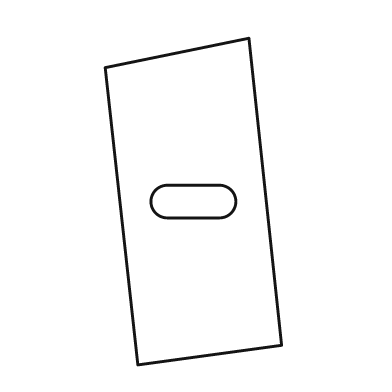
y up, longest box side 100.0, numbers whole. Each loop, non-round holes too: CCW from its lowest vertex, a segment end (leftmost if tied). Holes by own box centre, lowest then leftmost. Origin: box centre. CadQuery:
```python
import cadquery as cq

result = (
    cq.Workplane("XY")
    .moveTo(-17.0, -50.0)
    .lineTo(27.0, -44.0)
    .lineTo(17.0, 50.0)
    .lineTo(-27.0, 41.0)
    .close()
    .moveTo(-8.0, -5.0)
    .lineTo(8.0, -5.0)
    .threePointArc((13.0, 0.0), (8.0, 5.0))
    .lineTo(-8.0, 5.0)
    .threePointArc((-13.0, 0.0), (-8.0, -5.0))
    .close()
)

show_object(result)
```